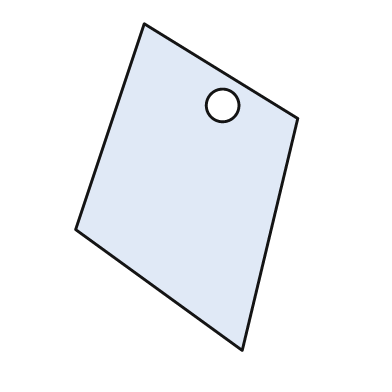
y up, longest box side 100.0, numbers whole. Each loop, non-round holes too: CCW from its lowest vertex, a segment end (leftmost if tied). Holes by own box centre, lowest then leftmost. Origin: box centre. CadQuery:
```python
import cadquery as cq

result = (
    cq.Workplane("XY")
    .moveTo(17.0, -50.0)
    .lineTo(34.0, 21.0)
    .lineTo(-13.0, 50.0)
    .lineTo(-34.0, -13.0)
    .close()
    .moveTo(11.0, 25.0)
    .circle(5.0)
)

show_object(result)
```